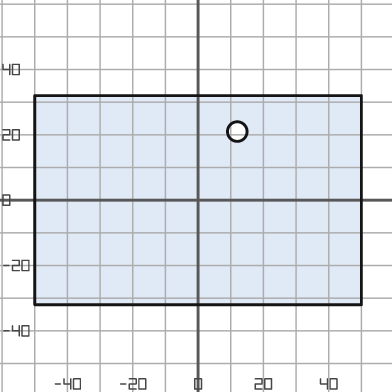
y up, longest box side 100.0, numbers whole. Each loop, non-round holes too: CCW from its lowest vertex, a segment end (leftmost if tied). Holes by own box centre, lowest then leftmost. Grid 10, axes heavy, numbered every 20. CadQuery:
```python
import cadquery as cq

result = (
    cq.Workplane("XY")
    .moveTo(-50.0, -32.0)
    .lineTo(50.0, -32.0)
    .lineTo(50.0, 32.0)
    .lineTo(-50.0, 32.0)
    .close()
    .moveTo(12.0, 21.0)
    .circle(3.0)
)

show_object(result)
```